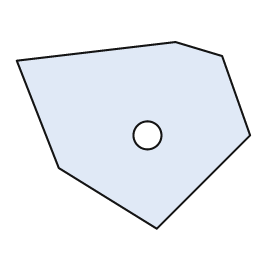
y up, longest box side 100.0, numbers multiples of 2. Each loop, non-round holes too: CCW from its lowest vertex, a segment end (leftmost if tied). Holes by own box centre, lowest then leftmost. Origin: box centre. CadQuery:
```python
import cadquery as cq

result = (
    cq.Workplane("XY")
    .moveTo(10.0, -40.0)
    .lineTo(50.0, 0.0)
    .lineTo(38.0, 34.0)
    .lineTo(18.0, 40.0)
    .lineTo(-50.0, 32.0)
    .lineTo(-32.0, -14.0)
    .close()
    .moveTo(6.0, 0.0)
    .circle(6.0)
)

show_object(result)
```